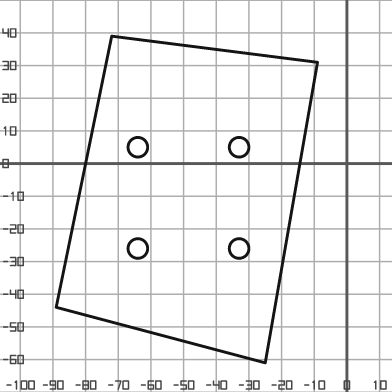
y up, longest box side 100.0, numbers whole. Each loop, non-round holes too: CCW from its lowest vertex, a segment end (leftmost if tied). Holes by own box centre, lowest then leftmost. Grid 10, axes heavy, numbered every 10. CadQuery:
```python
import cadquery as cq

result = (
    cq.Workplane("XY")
    .moveTo(-25.0, -61.0)
    .lineTo(-9.0, 31.0)
    .lineTo(-72.0, 39.0)
    .lineTo(-89.0, -44.0)
    .close()
    .moveTo(-64.0, -26.0)
    .circle(3.0)
    .moveTo(-33.0, -26.0)
    .circle(3.0)
    .moveTo(-64.0, 5.0)
    .circle(3.0)
    .moveTo(-33.0, 5.0)
    .circle(3.0)
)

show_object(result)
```